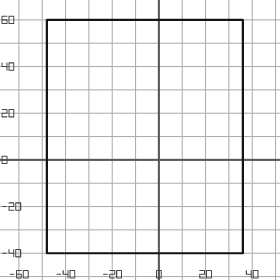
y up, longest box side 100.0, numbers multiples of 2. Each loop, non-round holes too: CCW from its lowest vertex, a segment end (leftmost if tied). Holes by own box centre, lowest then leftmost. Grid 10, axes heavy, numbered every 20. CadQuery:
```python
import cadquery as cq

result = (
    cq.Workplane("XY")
    .moveTo(-48.0, -40.0)
    .lineTo(36.0, -40.0)
    .lineTo(36.0, 60.0)
    .lineTo(-48.0, 60.0)
    .close()
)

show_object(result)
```